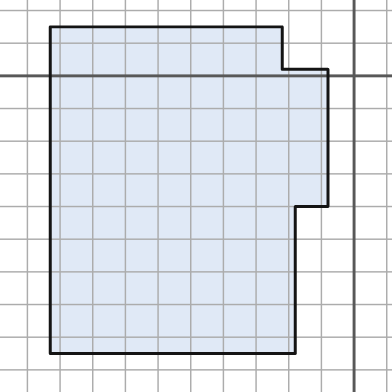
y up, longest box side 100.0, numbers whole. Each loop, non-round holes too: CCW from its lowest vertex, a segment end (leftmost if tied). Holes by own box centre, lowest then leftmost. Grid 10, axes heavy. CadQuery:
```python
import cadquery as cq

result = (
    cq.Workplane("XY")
    .moveTo(-93.0, -85.0)
    .lineTo(-18.0, -85.0)
    .lineTo(-18.0, -40.0)
    .lineTo(-8.0, -40.0)
    .lineTo(-8.0, 2.0)
    .lineTo(-22.0, 2.0)
    .lineTo(-22.0, 15.0)
    .lineTo(-93.0, 15.0)
    .close()
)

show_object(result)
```